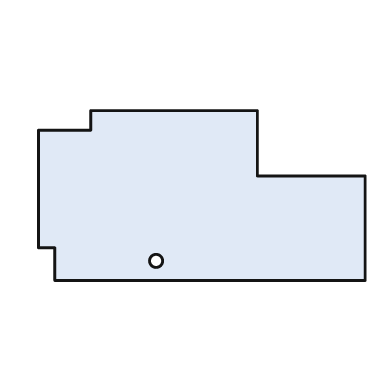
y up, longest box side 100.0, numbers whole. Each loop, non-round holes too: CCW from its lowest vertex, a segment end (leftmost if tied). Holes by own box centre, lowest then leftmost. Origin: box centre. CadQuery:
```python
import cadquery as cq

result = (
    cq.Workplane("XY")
    .moveTo(-45.0, -26.0)
    .lineTo(50.0, -26.0)
    .lineTo(50.0, 6.0)
    .lineTo(17.0, 6.0)
    .lineTo(17.0, 26.0)
    .lineTo(-34.0, 26.0)
    .lineTo(-34.0, 20.0)
    .lineTo(-50.0, 20.0)
    .lineTo(-50.0, -16.0)
    .lineTo(-45.0, -16.0)
    .close()
    .moveTo(-14.0, -20.0)
    .circle(2.0)
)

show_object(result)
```